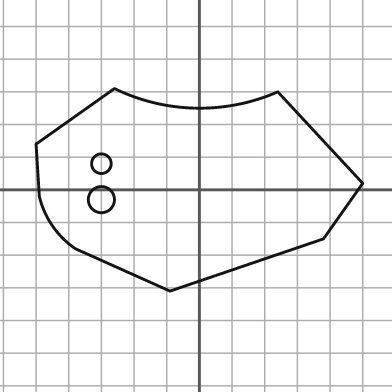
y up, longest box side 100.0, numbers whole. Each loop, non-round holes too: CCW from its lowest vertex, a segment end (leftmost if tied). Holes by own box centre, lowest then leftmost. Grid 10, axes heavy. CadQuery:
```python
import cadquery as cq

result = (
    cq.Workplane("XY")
    .moveTo(-9.0, -31.0)
    .lineTo(38.0, -15.0)
    .lineTo(50.0, 2.0)
    .lineTo(24.0, 30.0)
    .threePointArc((-1.0, 25.0), (-26.0, 31.0))
    .lineTo(-50.0, 14.0)
    .lineTo(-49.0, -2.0)
    .threePointArc((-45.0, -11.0), (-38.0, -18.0))
    .close()
    .moveTo(-30.0, -3.0)
    .circle(4.0)
    .moveTo(-30.0, 8.0)
    .circle(3.0)
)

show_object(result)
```